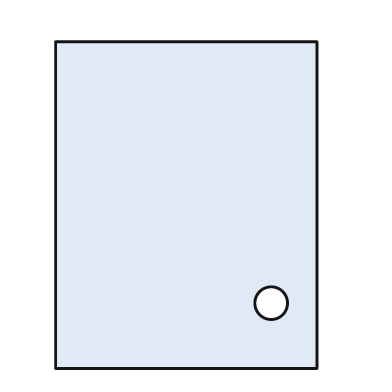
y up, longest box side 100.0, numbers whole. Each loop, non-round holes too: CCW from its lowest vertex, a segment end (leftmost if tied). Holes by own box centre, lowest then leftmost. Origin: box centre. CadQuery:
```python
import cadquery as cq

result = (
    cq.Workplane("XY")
    .moveTo(-40.0, -50.0)
    .lineTo(40.0, -50.0)
    .lineTo(40.0, 50.0)
    .lineTo(-40.0, 50.0)
    .close()
    .moveTo(26.0, -30.0)
    .circle(5.0)
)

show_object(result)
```